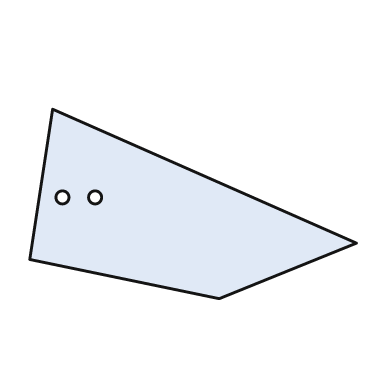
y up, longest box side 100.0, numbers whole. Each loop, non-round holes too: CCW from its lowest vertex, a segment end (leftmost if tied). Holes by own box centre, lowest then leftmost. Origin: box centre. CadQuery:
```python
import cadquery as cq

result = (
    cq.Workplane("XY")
    .moveTo(8.0, -29.0)
    .lineTo(50.0, -12.0)
    .lineTo(-43.0, 29.0)
    .lineTo(-50.0, -17.0)
    .close()
    .moveTo(-40.0, 2.0)
    .circle(2.0)
    .moveTo(-30.0, 2.0)
    .circle(2.0)
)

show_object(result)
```